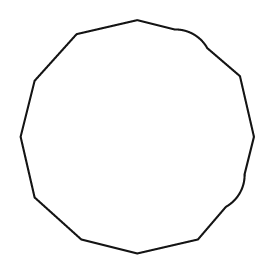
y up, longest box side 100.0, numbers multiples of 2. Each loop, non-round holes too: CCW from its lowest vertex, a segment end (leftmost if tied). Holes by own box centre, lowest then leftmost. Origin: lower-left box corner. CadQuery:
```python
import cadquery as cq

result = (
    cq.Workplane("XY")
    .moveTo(50.0, 0.0)
    .lineTo(76.0, 6.0)
    .lineTo(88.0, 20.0)
    .threePointArc((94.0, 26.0), (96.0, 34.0))
    .lineTo(100.0, 50.0)
    .lineTo(94.0, 76.0)
    .lineTo(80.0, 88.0)
    .threePointArc((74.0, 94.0), (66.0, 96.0))
    .lineTo(50.0, 100.0)
    .lineTo(24.0, 94.0)
    .lineTo(6.0, 74.0)
    .lineTo(0.0, 50.0)
    .lineTo(6.0, 24.0)
    .lineTo(26.0, 6.0)
    .close()
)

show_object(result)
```